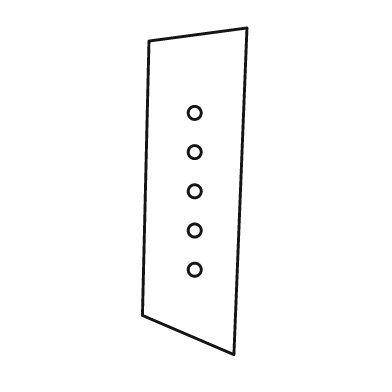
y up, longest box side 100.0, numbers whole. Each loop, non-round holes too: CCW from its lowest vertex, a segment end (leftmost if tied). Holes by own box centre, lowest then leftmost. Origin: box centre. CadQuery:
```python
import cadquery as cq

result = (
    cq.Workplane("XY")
    .moveTo(12.0, -50.0)
    .lineTo(16.0, 50.0)
    .lineTo(-14.0, 46.0)
    .lineTo(-16.0, -38.0)
    .close()
    .moveTo(0.0, -24.0)
    .circle(2.0)
    .moveTo(0.0, -12.0)
    .circle(2.0)
    .moveTo(0.0, 0.0)
    .circle(2.0)
    .moveTo(0.0, 12.0)
    .circle(2.0)
    .moveTo(0.0, 24.0)
    .circle(2.0)
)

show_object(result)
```